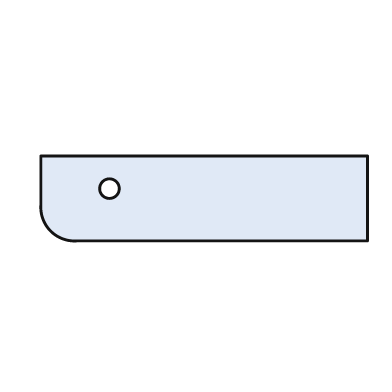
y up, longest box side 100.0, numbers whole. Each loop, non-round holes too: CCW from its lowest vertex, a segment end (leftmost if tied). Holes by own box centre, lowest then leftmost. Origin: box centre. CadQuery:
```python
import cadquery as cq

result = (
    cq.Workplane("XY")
    .moveTo(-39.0, -13.0)
    .lineTo(50.0, -13.0)
    .lineTo(50.0, 13.0)
    .lineTo(-50.0, 13.0)
    .lineTo(-50.0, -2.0)
    .threePointArc((-47.0, -10.0), (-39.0, -13.0))
    .close()
    .moveTo(-29.0, 3.0)
    .circle(3.0)
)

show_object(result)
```